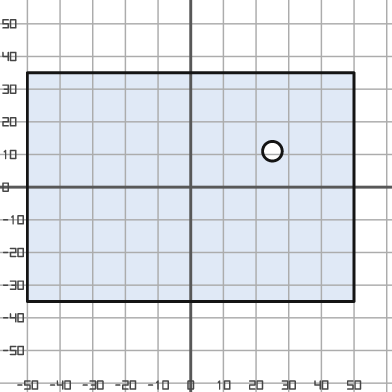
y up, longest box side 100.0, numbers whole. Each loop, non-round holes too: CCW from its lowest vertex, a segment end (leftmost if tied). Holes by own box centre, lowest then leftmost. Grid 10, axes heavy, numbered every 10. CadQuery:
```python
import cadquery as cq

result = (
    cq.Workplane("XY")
    .moveTo(-50.0, -35.0)
    .lineTo(50.0, -35.0)
    .lineTo(50.0, 35.0)
    .lineTo(-50.0, 35.0)
    .close()
    .moveTo(25.0, 11.0)
    .circle(3.0)
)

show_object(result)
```